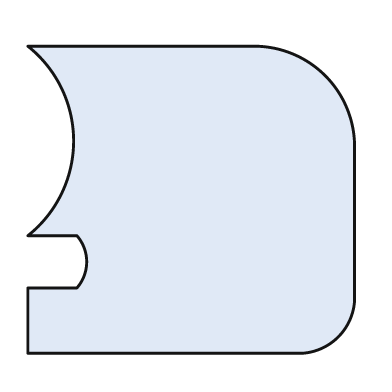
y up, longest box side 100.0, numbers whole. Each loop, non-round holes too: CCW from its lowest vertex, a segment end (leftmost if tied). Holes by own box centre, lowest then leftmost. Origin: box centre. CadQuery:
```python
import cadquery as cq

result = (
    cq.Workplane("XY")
    .moveTo(-50.0, -47.0)
    .lineTo(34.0, -47.0)
    .threePointArc((45.0, -42.0), (50.0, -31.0))
    .lineTo(50.0, 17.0)
    .threePointArc((41.0, 38.0), (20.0, 47.0))
    .lineTo(-50.0, 47.0)
    .threePointArc((-36.0, 18.0), (-50.0, -11.0))
    .lineTo(-35.0, -11.0)
    .threePointArc((-32.0, -19.0), (-35.0, -27.0))
    .lineTo(-50.0, -27.0)
    .close()
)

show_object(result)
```